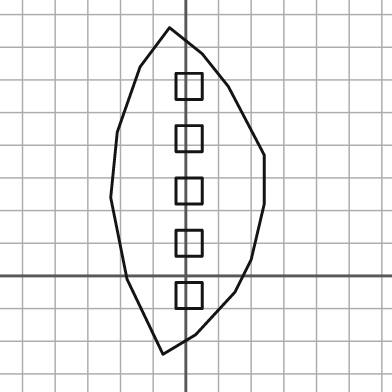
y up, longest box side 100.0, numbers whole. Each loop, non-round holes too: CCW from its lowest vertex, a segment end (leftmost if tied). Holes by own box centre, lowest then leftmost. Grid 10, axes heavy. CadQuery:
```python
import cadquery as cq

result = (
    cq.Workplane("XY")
    .moveTo(-7.0, -24.0)
    .lineTo(3.0, -18.0)
    .lineTo(15.0, -5.0)
    .lineTo(20.0, 5.0)
    .lineTo(24.0, 22.0)
    .lineTo(24.0, 37.0)
    .lineTo(13.0, 58.0)
    .lineTo(5.0, 68.0)
    .lineTo(-5.0, 76.0)
    .lineTo(-14.0, 64.0)
    .lineTo(-21.0, 44.0)
    .lineTo(-23.0, 24.0)
    .lineTo(-18.0, -1.0)
    .close()
    .moveTo(-3.0, -10.0)
    .lineTo(5.0, -10.0)
    .lineTo(5.0, -2.0)
    .lineTo(-3.0, -2.0)
    .close()
    .moveTo(-3.0, 6.0)
    .lineTo(5.0, 6.0)
    .lineTo(5.0, 14.0)
    .lineTo(-3.0, 14.0)
    .close()
    .moveTo(-3.0, 22.0)
    .lineTo(5.0, 22.0)
    .lineTo(5.0, 30.0)
    .lineTo(-3.0, 30.0)
    .close()
    .moveTo(-3.0, 38.0)
    .lineTo(5.0, 38.0)
    .lineTo(5.0, 46.0)
    .lineTo(-3.0, 46.0)
    .close()
    .moveTo(-3.0, 54.0)
    .lineTo(5.0, 54.0)
    .lineTo(5.0, 62.0)
    .lineTo(-3.0, 62.0)
    .close()
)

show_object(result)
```